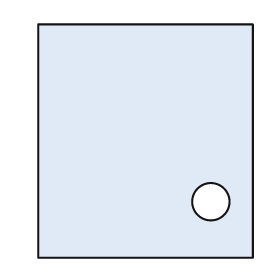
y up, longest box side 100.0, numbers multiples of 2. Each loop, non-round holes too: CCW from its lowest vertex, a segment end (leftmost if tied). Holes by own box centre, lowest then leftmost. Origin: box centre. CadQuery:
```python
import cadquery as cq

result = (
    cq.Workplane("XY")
    .moveTo(-46.0, -50.0)
    .lineTo(46.0, -50.0)
    .lineTo(46.0, 50.0)
    .lineTo(-46.0, 50.0)
    .close()
    .moveTo(28.0, -26.0)
    .circle(8.0)
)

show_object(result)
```